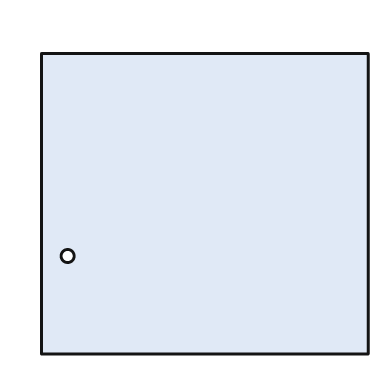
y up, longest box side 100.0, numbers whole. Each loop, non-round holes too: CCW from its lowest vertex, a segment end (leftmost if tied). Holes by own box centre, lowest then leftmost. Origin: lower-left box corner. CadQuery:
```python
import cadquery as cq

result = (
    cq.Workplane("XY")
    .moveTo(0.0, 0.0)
    .lineTo(100.0, 0.0)
    .lineTo(100.0, 92.0)
    .lineTo(0.0, 92.0)
    .close()
    .moveTo(8.0, 30.0)
    .circle(2.0)
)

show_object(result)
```